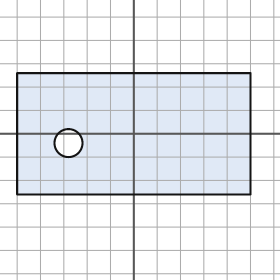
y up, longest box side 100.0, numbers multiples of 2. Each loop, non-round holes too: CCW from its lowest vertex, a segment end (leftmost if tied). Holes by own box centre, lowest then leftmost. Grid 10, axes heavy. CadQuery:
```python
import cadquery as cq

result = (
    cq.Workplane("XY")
    .moveTo(-50.0, -26.0)
    .lineTo(50.0, -26.0)
    .lineTo(50.0, 26.0)
    .lineTo(-50.0, 26.0)
    .close()
    .moveTo(-28.0, -4.0)
    .circle(6.0)
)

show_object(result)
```